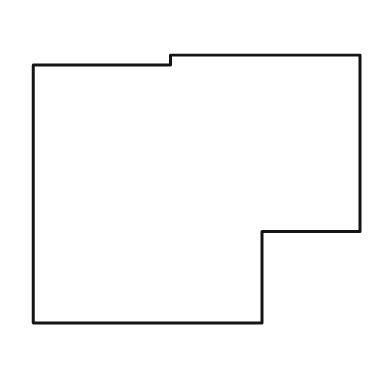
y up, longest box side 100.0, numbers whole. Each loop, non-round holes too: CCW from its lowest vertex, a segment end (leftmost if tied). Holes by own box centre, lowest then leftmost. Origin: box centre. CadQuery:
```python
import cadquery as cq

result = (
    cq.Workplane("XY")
    .moveTo(-50.0, -41.0)
    .lineTo(20.0, -41.0)
    .lineTo(20.0, -13.0)
    .lineTo(50.0, -13.0)
    .lineTo(50.0, 41.0)
    .lineTo(-8.0, 41.0)
    .lineTo(-8.0, 38.0)
    .lineTo(-50.0, 38.0)
    .close()
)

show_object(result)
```